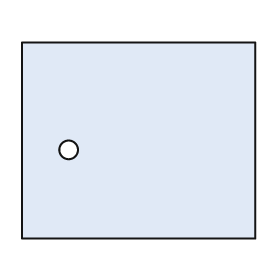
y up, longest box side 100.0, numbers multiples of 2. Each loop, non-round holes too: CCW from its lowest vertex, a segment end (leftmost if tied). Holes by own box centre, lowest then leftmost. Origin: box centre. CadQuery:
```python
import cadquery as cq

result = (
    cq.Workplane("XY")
    .moveTo(-50.0, -42.0)
    .lineTo(50.0, -42.0)
    .lineTo(50.0, 42.0)
    .lineTo(-50.0, 42.0)
    .close()
    .moveTo(-30.0, -4.0)
    .circle(4.0)
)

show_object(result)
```